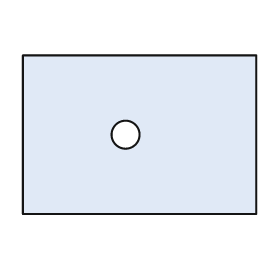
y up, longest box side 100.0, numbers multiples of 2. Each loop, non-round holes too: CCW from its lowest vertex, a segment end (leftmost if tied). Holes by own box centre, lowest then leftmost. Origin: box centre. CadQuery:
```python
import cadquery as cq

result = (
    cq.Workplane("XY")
    .moveTo(-50.0, -34.0)
    .lineTo(50.0, -34.0)
    .lineTo(50.0, 34.0)
    .lineTo(-50.0, 34.0)
    .close()
    .moveTo(-6.0, 0.0)
    .circle(6.0)
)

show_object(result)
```